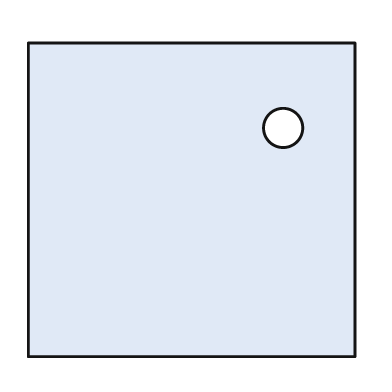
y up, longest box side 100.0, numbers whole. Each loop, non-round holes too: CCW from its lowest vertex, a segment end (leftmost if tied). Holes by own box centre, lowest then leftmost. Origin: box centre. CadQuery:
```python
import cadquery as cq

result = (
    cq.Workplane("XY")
    .moveTo(-50.0, -48.0)
    .lineTo(50.0, -48.0)
    .lineTo(50.0, 48.0)
    .lineTo(-50.0, 48.0)
    .close()
    .moveTo(28.0, 22.0)
    .circle(6.0)
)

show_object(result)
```